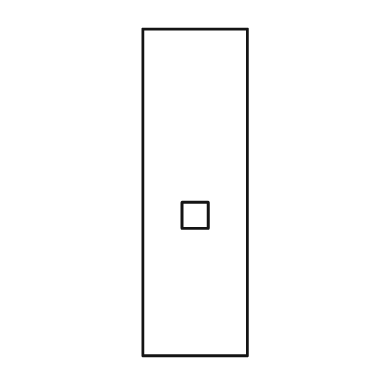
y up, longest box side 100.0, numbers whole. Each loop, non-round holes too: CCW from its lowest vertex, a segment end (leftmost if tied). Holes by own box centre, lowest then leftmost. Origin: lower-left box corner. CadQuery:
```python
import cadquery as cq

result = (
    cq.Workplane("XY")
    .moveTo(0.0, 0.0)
    .lineTo(32.0, 0.0)
    .lineTo(32.0, 100.0)
    .lineTo(0.0, 100.0)
    .close()
    .moveTo(12.0, 39.0)
    .lineTo(20.0, 39.0)
    .lineTo(20.0, 47.0)
    .lineTo(12.0, 47.0)
    .close()
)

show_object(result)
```